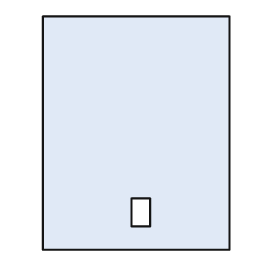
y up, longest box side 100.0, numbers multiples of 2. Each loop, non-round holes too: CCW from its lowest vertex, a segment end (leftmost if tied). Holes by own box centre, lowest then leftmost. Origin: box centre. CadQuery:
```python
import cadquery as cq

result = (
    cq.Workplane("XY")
    .moveTo(-40.0, -50.0)
    .lineTo(40.0, -50.0)
    .lineTo(40.0, 50.0)
    .lineTo(-40.0, 50.0)
    .close()
    .moveTo(-2.0, -40.0)
    .lineTo(6.0, -40.0)
    .lineTo(6.0, -28.0)
    .lineTo(-2.0, -28.0)
    .close()
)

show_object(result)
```